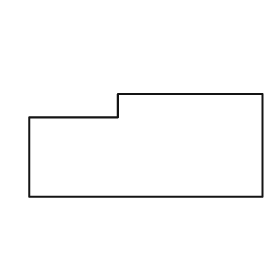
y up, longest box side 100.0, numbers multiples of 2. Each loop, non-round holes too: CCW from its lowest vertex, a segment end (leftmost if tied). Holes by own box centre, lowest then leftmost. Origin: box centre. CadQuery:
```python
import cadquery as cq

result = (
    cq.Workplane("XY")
    .moveTo(-50.0, -22.0)
    .lineTo(50.0, -22.0)
    .lineTo(50.0, 22.0)
    .lineTo(-12.0, 22.0)
    .lineTo(-12.0, 12.0)
    .lineTo(-50.0, 12.0)
    .close()
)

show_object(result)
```